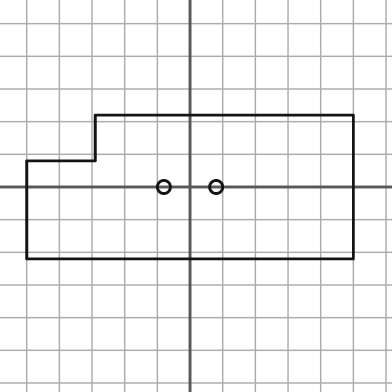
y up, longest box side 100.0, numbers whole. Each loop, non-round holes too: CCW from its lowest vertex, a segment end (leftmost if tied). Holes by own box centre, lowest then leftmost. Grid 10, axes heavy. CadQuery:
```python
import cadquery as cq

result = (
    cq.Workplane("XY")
    .moveTo(-50.0, -22.0)
    .lineTo(50.0, -22.0)
    .lineTo(50.0, 22.0)
    .lineTo(-29.0, 22.0)
    .lineTo(-29.0, 8.0)
    .lineTo(-50.0, 8.0)
    .close()
    .moveTo(-8.0, 0.0)
    .circle(2.0)
    .moveTo(8.0, 0.0)
    .circle(2.0)
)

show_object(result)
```